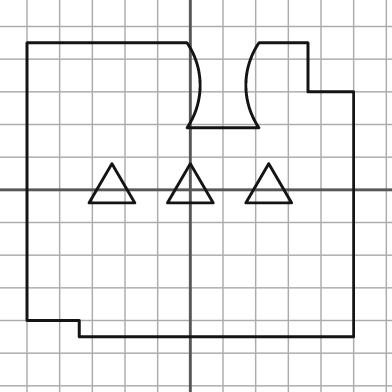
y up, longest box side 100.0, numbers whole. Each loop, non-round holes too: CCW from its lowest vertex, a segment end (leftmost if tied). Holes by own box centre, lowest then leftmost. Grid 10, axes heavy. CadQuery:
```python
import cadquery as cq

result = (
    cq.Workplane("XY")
    .moveTo(-34.0, -45.0)
    .lineTo(50.0, -45.0)
    .lineTo(50.0, 30.0)
    .lineTo(36.0, 30.0)
    .lineTo(36.0, 45.0)
    .lineTo(21.0, 45.0)
    .threePointArc((17.0, 32.0), (21.0, 19.0))
    .lineTo(-1.0, 19.0)
    .threePointArc((3.0, 32.0), (-1.0, 45.0))
    .lineTo(-50.0, 45.0)
    .lineTo(-50.0, -40.0)
    .lineTo(-34.0, -40.0)
    .close()
    .moveTo(-31.0, -4.0)
    .lineTo(-17.0, -4.0)
    .lineTo(-24.0, 8.0)
    .close()
    .moveTo(-7.0, -4.0)
    .lineTo(7.0, -4.0)
    .lineTo(0.0, 8.0)
    .close()
    .moveTo(17.0, -4.0)
    .lineTo(31.0, -4.0)
    .lineTo(24.0, 8.0)
    .close()
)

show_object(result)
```